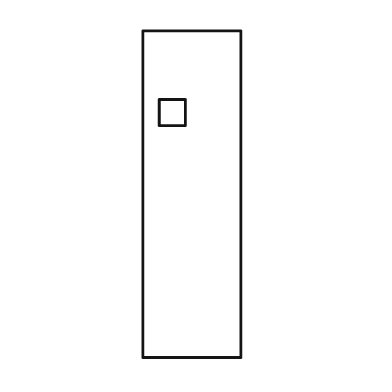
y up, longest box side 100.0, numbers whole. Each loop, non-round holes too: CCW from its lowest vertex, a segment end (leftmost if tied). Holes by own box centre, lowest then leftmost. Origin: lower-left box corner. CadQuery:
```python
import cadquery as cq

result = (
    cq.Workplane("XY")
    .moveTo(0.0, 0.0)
    .lineTo(30.0, 0.0)
    .lineTo(30.0, 100.0)
    .lineTo(0.0, 100.0)
    .close()
    .moveTo(5.0, 71.0)
    .lineTo(13.0, 71.0)
    .lineTo(13.0, 79.0)
    .lineTo(5.0, 79.0)
    .close()
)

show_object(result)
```